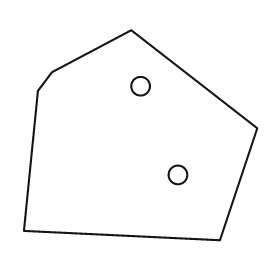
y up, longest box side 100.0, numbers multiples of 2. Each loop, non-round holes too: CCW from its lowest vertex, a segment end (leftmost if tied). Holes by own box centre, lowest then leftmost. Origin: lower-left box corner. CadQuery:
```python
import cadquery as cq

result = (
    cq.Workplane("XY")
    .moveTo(84.0, 0.0)
    .lineTo(100.0, 48.0)
    .lineTo(46.0, 90.0)
    .lineTo(12.0, 72.0)
    .lineTo(6.0, 64.0)
    .lineTo(0.0, 4.0)
    .close()
    .moveTo(66.0, 28.0)
    .circle(4.0)
    .moveTo(50.0, 66.0)
    .circle(4.0)
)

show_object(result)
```